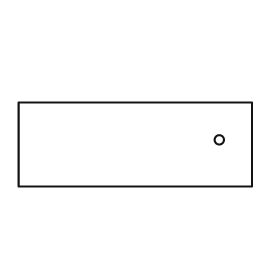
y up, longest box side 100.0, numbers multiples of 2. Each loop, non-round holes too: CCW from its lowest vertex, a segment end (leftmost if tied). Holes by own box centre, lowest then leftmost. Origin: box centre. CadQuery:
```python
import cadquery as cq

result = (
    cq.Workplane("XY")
    .moveTo(-50.0, -18.0)
    .lineTo(50.0, -18.0)
    .lineTo(50.0, 18.0)
    .lineTo(-50.0, 18.0)
    .close()
    .moveTo(36.0, 2.0)
    .circle(2.0)
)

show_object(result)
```